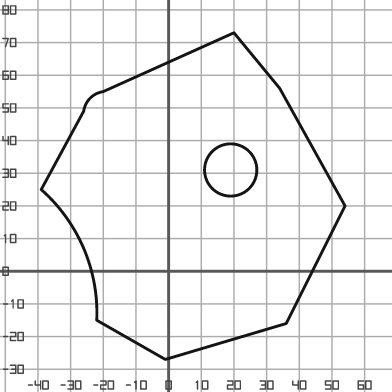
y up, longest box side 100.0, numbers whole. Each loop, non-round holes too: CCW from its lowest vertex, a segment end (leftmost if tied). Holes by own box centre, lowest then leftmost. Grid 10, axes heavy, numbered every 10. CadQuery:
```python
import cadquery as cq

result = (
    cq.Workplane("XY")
    .moveTo(-1.0, -27.0)
    .lineTo(36.0, -16.0)
    .lineTo(54.0, 20.0)
    .lineTo(34.0, 56.0)
    .lineTo(20.0, 73.0)
    .lineTo(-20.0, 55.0)
    .threePointArc((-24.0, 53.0), (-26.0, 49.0))
    .lineTo(-39.0, 25.0)
    .threePointArc((-26.0, 7.0), (-22.0, -15.0))
    .close()
    .moveTo(19.0, 31.0)
    .circle(8.0)
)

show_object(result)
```